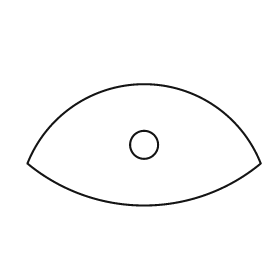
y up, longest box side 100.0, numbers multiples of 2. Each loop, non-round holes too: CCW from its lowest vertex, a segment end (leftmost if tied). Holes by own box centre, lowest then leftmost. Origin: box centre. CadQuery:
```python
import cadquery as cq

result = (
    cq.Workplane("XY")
    .moveTo(-50.0, -8.0)
    .threePointArc((0.0, -26.0), (50.0, -8.0))
    .threePointArc((0.0, 26.0), (-50.0, -8.0))
    .close()
    .moveTo(0.0, 0.0)
    .circle(6.0)
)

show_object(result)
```